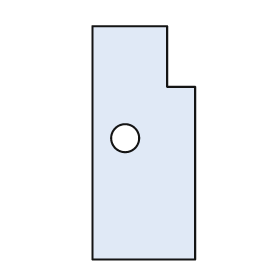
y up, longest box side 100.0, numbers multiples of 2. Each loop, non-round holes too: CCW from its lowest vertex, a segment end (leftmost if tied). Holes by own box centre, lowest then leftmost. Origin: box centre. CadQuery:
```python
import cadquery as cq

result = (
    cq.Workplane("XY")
    .moveTo(-22.0, -50.0)
    .lineTo(22.0, -50.0)
    .lineTo(22.0, 24.0)
    .lineTo(10.0, 24.0)
    .lineTo(10.0, 50.0)
    .lineTo(-22.0, 50.0)
    .close()
    .moveTo(-8.0, 2.0)
    .circle(6.0)
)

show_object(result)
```